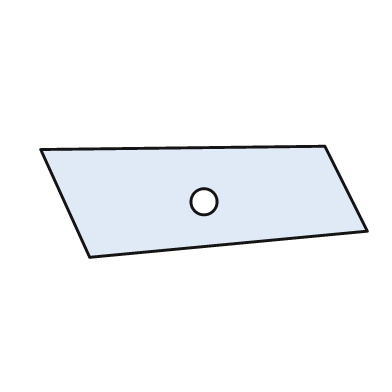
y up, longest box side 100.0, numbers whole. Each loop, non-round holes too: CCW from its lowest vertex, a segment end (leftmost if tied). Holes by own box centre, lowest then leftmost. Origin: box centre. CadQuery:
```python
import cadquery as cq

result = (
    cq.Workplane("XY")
    .moveTo(-35.0, -17.0)
    .lineTo(50.0, -9.0)
    .lineTo(37.0, 17.0)
    .lineTo(-50.0, 16.0)
    .close()
    .moveTo(0.0, 0.0)
    .circle(4.0)
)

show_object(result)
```